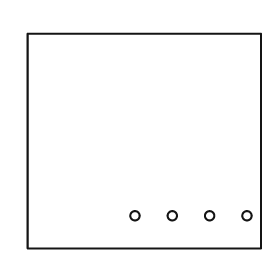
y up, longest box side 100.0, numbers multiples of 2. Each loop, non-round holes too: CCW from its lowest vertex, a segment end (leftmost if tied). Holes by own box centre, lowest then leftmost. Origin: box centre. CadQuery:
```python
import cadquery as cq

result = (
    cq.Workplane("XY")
    .moveTo(-50.0, -46.0)
    .lineTo(50.0, -46.0)
    .lineTo(50.0, 46.0)
    .lineTo(-50.0, 46.0)
    .close()
    .moveTo(-4.0, -32.0)
    .circle(2.0)
    .moveTo(12.0, -32.0)
    .circle(2.0)
    .moveTo(28.0, -32.0)
    .circle(2.0)
    .moveTo(44.0, -32.0)
    .circle(2.0)
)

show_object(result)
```